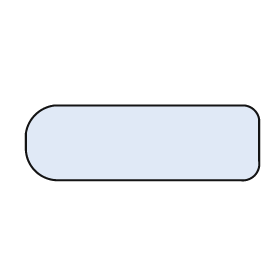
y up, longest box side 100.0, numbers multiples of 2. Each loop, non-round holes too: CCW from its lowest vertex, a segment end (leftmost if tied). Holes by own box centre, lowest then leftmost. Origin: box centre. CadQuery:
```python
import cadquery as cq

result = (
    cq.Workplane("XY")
    .moveTo(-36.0, -16.0)
    .lineTo(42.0, -16.0)
    .threePointArc((48.0, -14.0), (50.0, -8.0))
    .lineTo(50.0, 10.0)
    .threePointArc((48.0, 14.0), (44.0, 16.0))
    .lineTo(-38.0, 16.0)
    .threePointArc((-46.0, 12.0), (-50.0, 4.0))
    .lineTo(-50.0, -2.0)
    .threePointArc((-46.0, -12.0), (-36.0, -16.0))
    .close()
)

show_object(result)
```